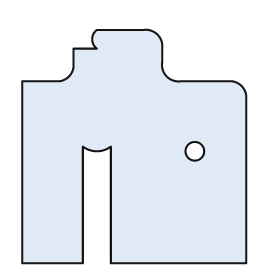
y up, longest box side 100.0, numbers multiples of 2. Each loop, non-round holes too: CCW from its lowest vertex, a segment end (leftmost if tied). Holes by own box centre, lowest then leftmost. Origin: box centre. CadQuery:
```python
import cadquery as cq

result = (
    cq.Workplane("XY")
    .moveTo(-48.0, -50.0)
    .lineTo(-22.0, -50.0)
    .lineTo(-22.0, 0.0)
    .threePointArc((-16.0, -2.0), (-10.0, 0.0))
    .lineTo(-10.0, -50.0)
    .lineTo(48.0, -50.0)
    .lineTo(48.0, 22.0)
    .threePointArc((46.0, 26.0), (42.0, 28.0))
    .lineTo(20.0, 28.0)
    .threePointArc((14.0, 30.0), (12.0, 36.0))
    .lineTo(12.0, 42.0)
    .threePointArc((10.0, 48.0), (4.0, 50.0))
    .lineTo(-16.0, 50.0)
    .threePointArc((-18.0, 46.0), (-16.0, 42.0))
    .lineTo(-26.0, 42.0)
    .lineTo(-26.0, 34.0)
    .threePointArc((-28.0, 30.0), (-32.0, 28.0))
    .lineTo(-48.0, 28.0)
    .close()
    .moveTo(26.0, -2.0)
    .circle(4.0)
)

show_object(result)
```